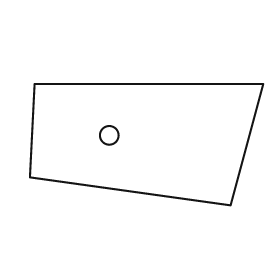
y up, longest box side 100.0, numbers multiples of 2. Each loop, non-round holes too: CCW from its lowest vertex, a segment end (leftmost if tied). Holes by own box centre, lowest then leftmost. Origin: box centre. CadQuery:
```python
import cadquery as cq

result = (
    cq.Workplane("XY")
    .moveTo(36.0, -26.0)
    .lineTo(50.0, 26.0)
    .lineTo(-48.0, 26.0)
    .lineTo(-50.0, -14.0)
    .close()
    .moveTo(-16.0, 4.0)
    .circle(4.0)
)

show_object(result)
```